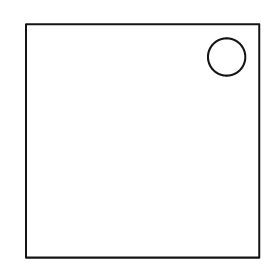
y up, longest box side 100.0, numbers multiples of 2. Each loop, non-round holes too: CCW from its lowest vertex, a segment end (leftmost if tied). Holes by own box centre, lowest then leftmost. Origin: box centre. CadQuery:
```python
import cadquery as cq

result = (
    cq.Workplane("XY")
    .moveTo(-50.0, -50.0)
    .lineTo(50.0, -50.0)
    .lineTo(50.0, 50.0)
    .lineTo(-50.0, 50.0)
    .close()
    .moveTo(36.0, 36.0)
    .circle(8.0)
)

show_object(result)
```